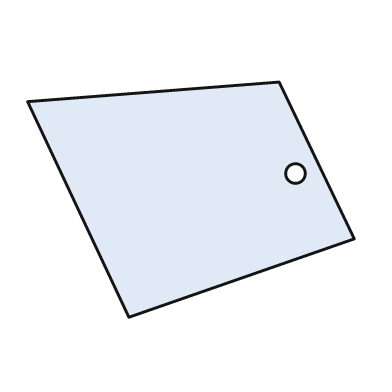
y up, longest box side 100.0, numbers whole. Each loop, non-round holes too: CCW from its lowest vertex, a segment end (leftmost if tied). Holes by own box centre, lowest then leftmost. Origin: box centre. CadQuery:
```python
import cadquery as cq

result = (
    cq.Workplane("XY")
    .moveTo(-19.0, -36.0)
    .lineTo(50.0, -12.0)
    .lineTo(27.0, 36.0)
    .lineTo(-50.0, 30.0)
    .close()
    .moveTo(32.0, 8.0)
    .circle(3.0)
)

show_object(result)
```